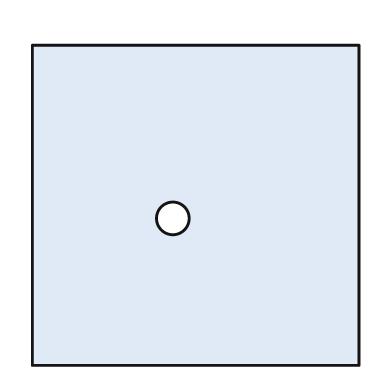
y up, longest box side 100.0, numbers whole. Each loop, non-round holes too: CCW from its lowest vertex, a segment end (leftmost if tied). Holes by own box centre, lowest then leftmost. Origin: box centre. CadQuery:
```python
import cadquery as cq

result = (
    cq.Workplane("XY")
    .moveTo(-50.0, -49.0)
    .lineTo(50.0, -49.0)
    .lineTo(50.0, 49.0)
    .lineTo(-50.0, 49.0)
    .close()
    .moveTo(-7.0, -4.0)
    .circle(5.0)
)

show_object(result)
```